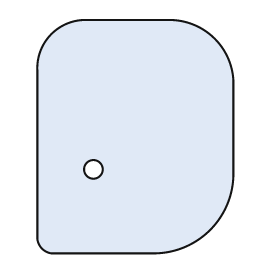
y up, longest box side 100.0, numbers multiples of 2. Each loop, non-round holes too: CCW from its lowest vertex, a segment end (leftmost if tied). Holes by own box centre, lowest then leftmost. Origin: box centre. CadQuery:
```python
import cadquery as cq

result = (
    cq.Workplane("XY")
    .moveTo(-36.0, -50.0)
    .lineTo(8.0, -50.0)
    .threePointArc((32.0, -40.0), (42.0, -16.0))
    .lineTo(42.0, 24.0)
    .threePointArc((34.0, 42.0), (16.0, 50.0))
    .lineTo(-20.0, 50.0)
    .threePointArc((-36.0, 44.0), (-42.0, 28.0))
    .lineTo(-42.0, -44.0)
    .threePointArc((-40.0, -48.0), (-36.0, -50.0))
    .close()
    .moveTo(-18.0, -14.0)
    .circle(4.0)
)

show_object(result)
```